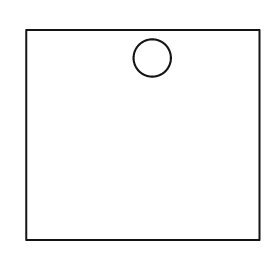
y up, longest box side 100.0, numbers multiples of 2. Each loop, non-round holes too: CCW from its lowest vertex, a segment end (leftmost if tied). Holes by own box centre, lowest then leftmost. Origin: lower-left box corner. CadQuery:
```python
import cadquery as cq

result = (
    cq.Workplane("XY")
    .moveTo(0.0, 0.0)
    .lineTo(100.0, 0.0)
    .lineTo(100.0, 90.0)
    .lineTo(0.0, 90.0)
    .close()
    .moveTo(54.0, 78.0)
    .circle(8.0)
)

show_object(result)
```